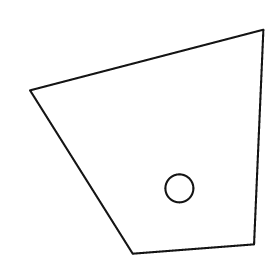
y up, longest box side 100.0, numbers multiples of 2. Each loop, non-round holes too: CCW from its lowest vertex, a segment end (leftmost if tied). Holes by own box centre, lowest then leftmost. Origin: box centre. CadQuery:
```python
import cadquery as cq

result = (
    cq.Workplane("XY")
    .moveTo(-6.0, -48.0)
    .lineTo(46.0, -44.0)
    .lineTo(50.0, 48.0)
    .lineTo(-50.0, 22.0)
    .close()
    .moveTo(14.0, -20.0)
    .circle(6.0)
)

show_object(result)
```